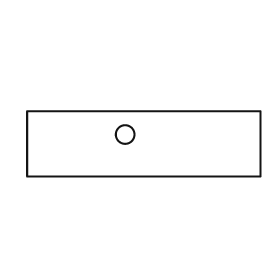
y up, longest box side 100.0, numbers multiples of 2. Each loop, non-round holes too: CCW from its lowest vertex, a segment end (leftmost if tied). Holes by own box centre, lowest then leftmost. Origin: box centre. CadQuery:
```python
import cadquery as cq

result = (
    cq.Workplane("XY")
    .moveTo(-50.0, -14.0)
    .lineTo(50.0, -14.0)
    .lineTo(50.0, 14.0)
    .lineTo(-50.0, 14.0)
    .close()
    .moveTo(-8.0, 4.0)
    .circle(4.0)
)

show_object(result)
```